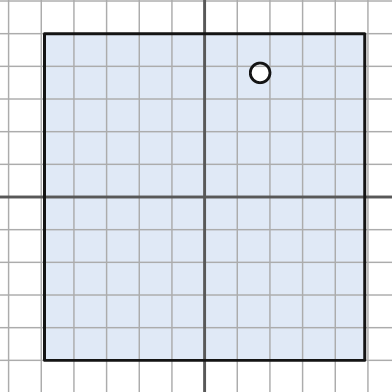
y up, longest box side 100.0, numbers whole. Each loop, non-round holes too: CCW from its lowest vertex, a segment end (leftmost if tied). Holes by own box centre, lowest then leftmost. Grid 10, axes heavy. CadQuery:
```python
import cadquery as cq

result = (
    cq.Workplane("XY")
    .moveTo(-49.0, -50.0)
    .lineTo(49.0, -50.0)
    .lineTo(49.0, 50.0)
    .lineTo(-49.0, 50.0)
    .close()
    .moveTo(17.0, 38.0)
    .circle(3.0)
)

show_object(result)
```